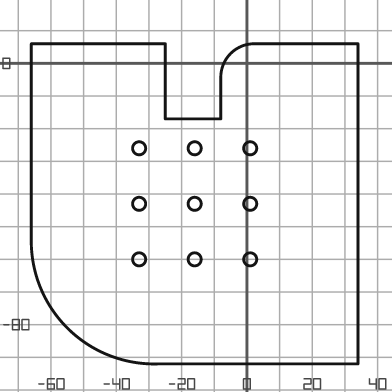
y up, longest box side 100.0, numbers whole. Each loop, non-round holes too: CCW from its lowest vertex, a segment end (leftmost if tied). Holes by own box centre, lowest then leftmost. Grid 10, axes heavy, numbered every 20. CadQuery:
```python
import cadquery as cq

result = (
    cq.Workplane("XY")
    .moveTo(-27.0, -92.0)
    .lineTo(34.0, -92.0)
    .lineTo(34.0, 6.0)
    .lineTo(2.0, 6.0)
    .threePointArc((-5.0, 3.0), (-8.0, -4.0))
    .lineTo(-8.0, -17.0)
    .lineTo(-25.0, -17.0)
    .lineTo(-25.0, 6.0)
    .lineTo(-66.0, 6.0)
    .lineTo(-66.0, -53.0)
    .threePointArc((-55.0, -81.0), (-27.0, -92.0))
    .close()
    .moveTo(-33.0, -60.0)
    .circle(2.0)
    .moveTo(-16.0, -60.0)
    .circle(2.0)
    .moveTo(1.0, -60.0)
    .circle(2.0)
    .moveTo(-33.0, -43.0)
    .circle(2.0)
    .moveTo(-16.0, -43.0)
    .circle(2.0)
    .moveTo(1.0, -43.0)
    .circle(2.0)
    .moveTo(-33.0, -26.0)
    .circle(2.0)
    .moveTo(-16.0, -26.0)
    .circle(2.0)
    .moveTo(1.0, -26.0)
    .circle(2.0)
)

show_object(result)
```